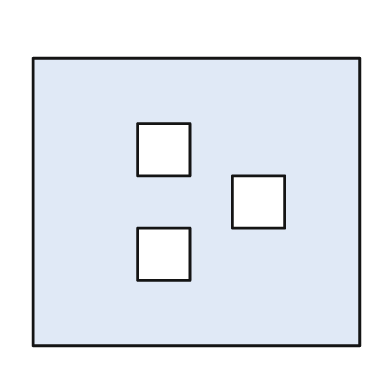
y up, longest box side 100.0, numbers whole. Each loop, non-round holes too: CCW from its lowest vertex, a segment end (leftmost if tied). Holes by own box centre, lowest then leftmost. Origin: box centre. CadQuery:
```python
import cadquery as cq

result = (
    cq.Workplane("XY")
    .moveTo(-50.0, -44.0)
    .lineTo(50.0, -44.0)
    .lineTo(50.0, 44.0)
    .lineTo(-50.0, 44.0)
    .close()
    .moveTo(-18.0, -24.0)
    .lineTo(-2.0, -24.0)
    .lineTo(-2.0, -8.0)
    .lineTo(-18.0, -8.0)
    .close()
    .moveTo(11.0, -8.0)
    .lineTo(27.0, -8.0)
    .lineTo(27.0, 8.0)
    .lineTo(11.0, 8.0)
    .close()
    .moveTo(-18.0, 8.0)
    .lineTo(-2.0, 8.0)
    .lineTo(-2.0, 24.0)
    .lineTo(-18.0, 24.0)
    .close()
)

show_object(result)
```